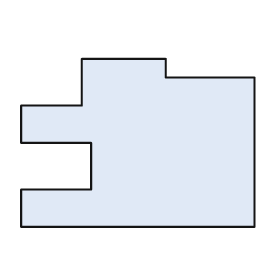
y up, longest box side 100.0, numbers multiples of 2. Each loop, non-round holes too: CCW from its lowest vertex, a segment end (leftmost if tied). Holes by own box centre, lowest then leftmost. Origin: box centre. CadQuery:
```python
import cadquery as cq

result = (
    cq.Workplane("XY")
    .moveTo(-50.0, -36.0)
    .lineTo(50.0, -36.0)
    .lineTo(50.0, 28.0)
    .lineTo(12.0, 28.0)
    .lineTo(12.0, 36.0)
    .lineTo(-24.0, 36.0)
    .lineTo(-24.0, 16.0)
    .lineTo(-50.0, 16.0)
    .lineTo(-50.0, 0.0)
    .lineTo(-20.0, 0.0)
    .lineTo(-20.0, -20.0)
    .lineTo(-50.0, -20.0)
    .close()
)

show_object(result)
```